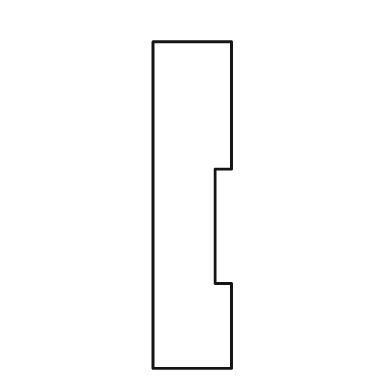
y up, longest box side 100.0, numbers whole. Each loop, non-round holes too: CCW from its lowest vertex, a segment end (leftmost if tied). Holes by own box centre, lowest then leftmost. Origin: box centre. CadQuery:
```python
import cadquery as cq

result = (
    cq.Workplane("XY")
    .moveTo(-12.0, -50.0)
    .lineTo(12.0, -50.0)
    .lineTo(12.0, -24.0)
    .lineTo(7.0, -24.0)
    .lineTo(7.0, 11.0)
    .lineTo(12.0, 11.0)
    .lineTo(12.0, 50.0)
    .lineTo(-12.0, 50.0)
    .close()
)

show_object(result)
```